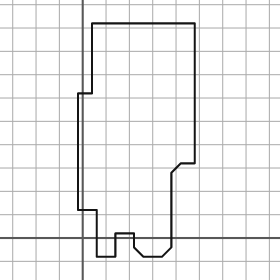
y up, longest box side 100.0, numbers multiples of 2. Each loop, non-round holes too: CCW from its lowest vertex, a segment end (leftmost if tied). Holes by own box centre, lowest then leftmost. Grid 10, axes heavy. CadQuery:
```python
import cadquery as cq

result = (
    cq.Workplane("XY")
    .moveTo(6.0, -8.0)
    .lineTo(14.0, -8.0)
    .lineTo(14.0, 2.0)
    .lineTo(22.0, 2.0)
    .lineTo(22.0, -4.0)
    .lineTo(26.0, -8.0)
    .lineTo(34.0, -8.0)
    .lineTo(38.0, -4.0)
    .lineTo(38.0, 28.0)
    .lineTo(42.0, 32.0)
    .lineTo(48.0, 32.0)
    .lineTo(48.0, 92.0)
    .lineTo(4.0, 92.0)
    .lineTo(4.0, 62.0)
    .lineTo(-2.0, 62.0)
    .lineTo(-2.0, 12.0)
    .lineTo(6.0, 12.0)
    .close()
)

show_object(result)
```